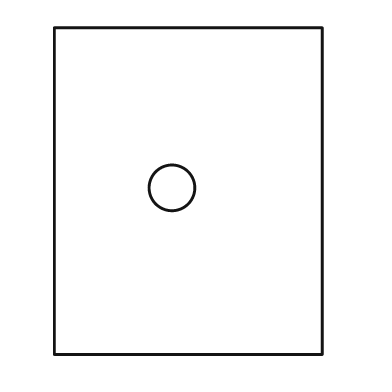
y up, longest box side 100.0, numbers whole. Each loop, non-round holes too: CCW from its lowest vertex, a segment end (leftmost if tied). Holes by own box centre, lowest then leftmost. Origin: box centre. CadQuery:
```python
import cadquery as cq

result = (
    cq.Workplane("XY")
    .moveTo(-41.0, -50.0)
    .lineTo(41.0, -50.0)
    .lineTo(41.0, 50.0)
    .lineTo(-41.0, 50.0)
    .close()
    .moveTo(-5.0, 1.0)
    .circle(7.0)
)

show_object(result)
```